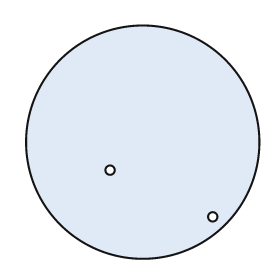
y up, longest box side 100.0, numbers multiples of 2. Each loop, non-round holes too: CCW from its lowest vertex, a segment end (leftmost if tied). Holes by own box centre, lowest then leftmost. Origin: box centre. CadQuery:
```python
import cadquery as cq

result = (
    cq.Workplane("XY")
    .moveTo(0.0, 0.0)
    .circle(50.0)
    .moveTo(30.0, -32.0)
    .circle(2.0)
    .moveTo(-14.0, -12.0)
    .circle(2.0)
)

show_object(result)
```